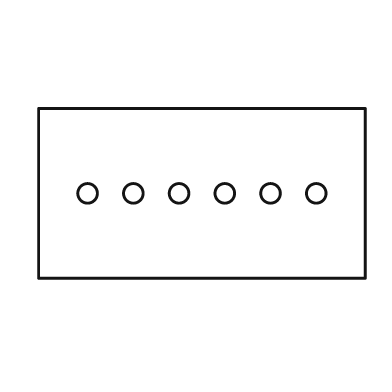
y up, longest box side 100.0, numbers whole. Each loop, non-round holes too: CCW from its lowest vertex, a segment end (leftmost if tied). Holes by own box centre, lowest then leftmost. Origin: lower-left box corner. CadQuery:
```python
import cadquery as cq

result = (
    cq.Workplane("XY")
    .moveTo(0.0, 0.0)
    .lineTo(100.0, 0.0)
    .lineTo(100.0, 52.0)
    .lineTo(0.0, 52.0)
    .close()
    .moveTo(15.0, 26.0)
    .circle(3.0)
    .moveTo(29.0, 26.0)
    .circle(3.0)
    .moveTo(43.0, 26.0)
    .circle(3.0)
    .moveTo(57.0, 26.0)
    .circle(3.0)
    .moveTo(71.0, 26.0)
    .circle(3.0)
    .moveTo(85.0, 26.0)
    .circle(3.0)
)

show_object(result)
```